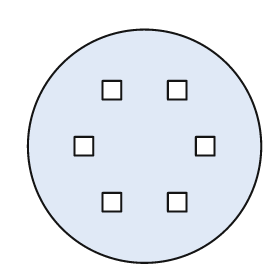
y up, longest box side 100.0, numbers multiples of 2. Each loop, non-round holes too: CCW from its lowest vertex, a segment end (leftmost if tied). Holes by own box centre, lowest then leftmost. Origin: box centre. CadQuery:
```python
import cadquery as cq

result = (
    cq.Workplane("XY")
    .moveTo(0.0, 0.0)
    .circle(50.0)
    .moveTo(-18.0, -28.0)
    .lineTo(-10.0, -28.0)
    .lineTo(-10.0, -20.0)
    .lineTo(-18.0, -20.0)
    .close()
    .moveTo(10.0, -28.0)
    .lineTo(18.0, -28.0)
    .lineTo(18.0, -20.0)
    .lineTo(10.0, -20.0)
    .close()
    .moveTo(-30.0, -4.0)
    .lineTo(-22.0, -4.0)
    .lineTo(-22.0, 4.0)
    .lineTo(-30.0, 4.0)
    .close()
    .moveTo(22.0, -4.0)
    .lineTo(30.0, -4.0)
    .lineTo(30.0, 4.0)
    .lineTo(22.0, 4.0)
    .close()
    .moveTo(-18.0, 20.0)
    .lineTo(-10.0, 20.0)
    .lineTo(-10.0, 28.0)
    .lineTo(-18.0, 28.0)
    .close()
    .moveTo(10.0, 20.0)
    .lineTo(18.0, 20.0)
    .lineTo(18.0, 28.0)
    .lineTo(10.0, 28.0)
    .close()
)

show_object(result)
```